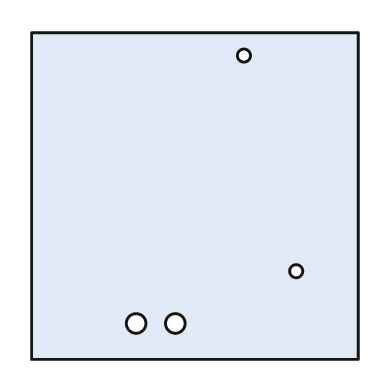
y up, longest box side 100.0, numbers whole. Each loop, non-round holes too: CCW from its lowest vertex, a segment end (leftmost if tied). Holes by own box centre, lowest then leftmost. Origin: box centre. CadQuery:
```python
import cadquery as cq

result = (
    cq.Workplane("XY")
    .moveTo(-50.0, -50.0)
    .lineTo(50.0, -50.0)
    .lineTo(50.0, 50.0)
    .lineTo(-50.0, 50.0)
    .close()
    .moveTo(-18.0, -39.0)
    .circle(3.0)
    .moveTo(-6.0, -39.0)
    .circle(3.0)
    .moveTo(31.0, -23.0)
    .circle(2.0)
    .moveTo(15.0, 43.0)
    .circle(2.0)
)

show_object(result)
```